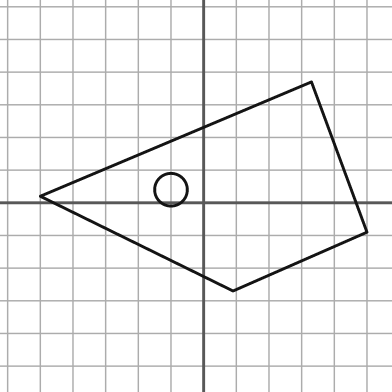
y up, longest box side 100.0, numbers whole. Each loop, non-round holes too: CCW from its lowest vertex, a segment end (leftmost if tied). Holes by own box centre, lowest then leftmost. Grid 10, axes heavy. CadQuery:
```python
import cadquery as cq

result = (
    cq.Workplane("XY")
    .moveTo(9.0, -27.0)
    .lineTo(50.0, -9.0)
    .lineTo(33.0, 37.0)
    .lineTo(-50.0, 2.0)
    .close()
    .moveTo(-10.0, 4.0)
    .circle(5.0)
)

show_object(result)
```